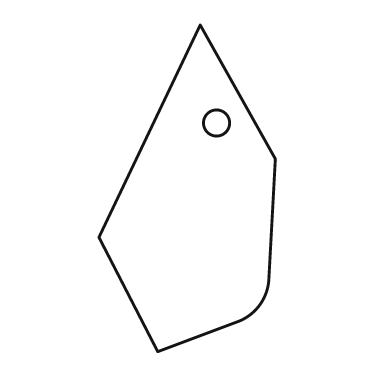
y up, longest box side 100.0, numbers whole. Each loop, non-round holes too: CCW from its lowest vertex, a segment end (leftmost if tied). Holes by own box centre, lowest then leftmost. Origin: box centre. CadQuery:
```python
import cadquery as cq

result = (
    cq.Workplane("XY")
    .moveTo(-9.0, -50.0)
    .lineTo(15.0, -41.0)
    .threePointArc((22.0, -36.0), (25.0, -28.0))
    .lineTo(27.0, 9.0)
    .lineTo(4.0, 50.0)
    .lineTo(-27.0, -15.0)
    .close()
    .moveTo(9.0, 20.0)
    .circle(4.0)
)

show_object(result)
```